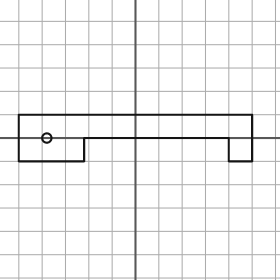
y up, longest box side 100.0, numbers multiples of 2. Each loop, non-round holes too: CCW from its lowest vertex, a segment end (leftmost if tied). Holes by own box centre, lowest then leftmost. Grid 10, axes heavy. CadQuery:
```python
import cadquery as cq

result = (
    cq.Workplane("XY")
    .moveTo(-50.0, -10.0)
    .lineTo(-22.0, -10.0)
    .lineTo(-22.0, 0.0)
    .lineTo(40.0, 0.0)
    .lineTo(40.0, -10.0)
    .lineTo(50.0, -10.0)
    .lineTo(50.0, 10.0)
    .lineTo(-50.0, 10.0)
    .close()
    .moveTo(-38.0, 0.0)
    .circle(2.0)
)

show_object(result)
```